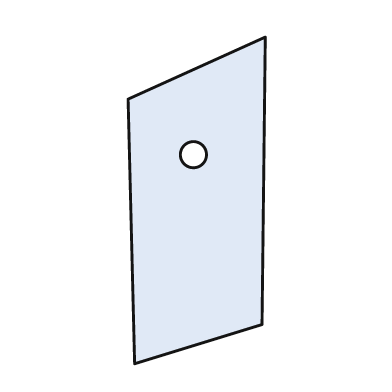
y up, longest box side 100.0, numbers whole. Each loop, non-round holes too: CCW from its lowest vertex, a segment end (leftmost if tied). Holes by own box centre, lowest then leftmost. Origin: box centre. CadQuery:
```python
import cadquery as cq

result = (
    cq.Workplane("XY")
    .moveTo(-19.0, -50.0)
    .lineTo(20.0, -38.0)
    .lineTo(21.0, 50.0)
    .lineTo(-21.0, 31.0)
    .close()
    .moveTo(-1.0, 14.0)
    .circle(4.0)
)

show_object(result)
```